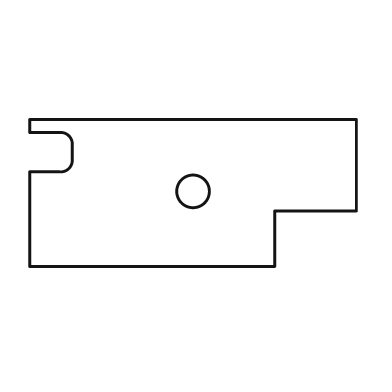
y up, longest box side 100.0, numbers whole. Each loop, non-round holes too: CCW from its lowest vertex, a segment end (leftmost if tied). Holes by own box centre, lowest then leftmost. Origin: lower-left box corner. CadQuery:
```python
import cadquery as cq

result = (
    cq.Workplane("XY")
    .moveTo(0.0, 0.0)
    .lineTo(75.0, 0.0)
    .lineTo(75.0, 17.0)
    .lineTo(100.0, 17.0)
    .lineTo(100.0, 45.0)
    .lineTo(0.0, 45.0)
    .lineTo(0.0, 41.0)
    .lineTo(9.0, 41.0)
    .threePointArc((12.0, 40.0), (13.0, 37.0))
    .lineTo(13.0, 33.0)
    .threePointArc((12.0, 30.0), (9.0, 29.0))
    .lineTo(0.0, 29.0)
    .close()
    .moveTo(50.0, 23.0)
    .circle(5.0)
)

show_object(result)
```